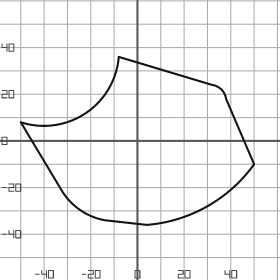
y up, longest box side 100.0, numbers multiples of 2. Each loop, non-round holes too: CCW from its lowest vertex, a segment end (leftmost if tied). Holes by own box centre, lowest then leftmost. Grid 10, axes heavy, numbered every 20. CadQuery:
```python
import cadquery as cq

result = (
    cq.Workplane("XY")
    .moveTo(4.0, -36.0)
    .threePointArc((30.0, -28.0), (50.0, -10.0))
    .lineTo(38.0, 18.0)
    .threePointArc((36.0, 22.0), (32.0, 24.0))
    .lineTo(-8.0, 36.0)
    .threePointArc((-22.0, 12.0), (-50.0, 8.0))
    .lineTo(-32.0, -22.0)
    .threePointArc((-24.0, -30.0), (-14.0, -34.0))
    .close()
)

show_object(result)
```